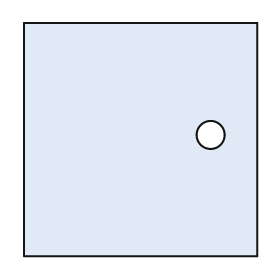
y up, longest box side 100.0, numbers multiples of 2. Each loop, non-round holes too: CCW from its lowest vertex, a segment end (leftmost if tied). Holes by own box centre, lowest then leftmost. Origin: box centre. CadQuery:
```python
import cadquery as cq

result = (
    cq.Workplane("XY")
    .moveTo(-50.0, -50.0)
    .lineTo(50.0, -50.0)
    .lineTo(50.0, 50.0)
    .lineTo(-50.0, 50.0)
    .close()
    .moveTo(30.0, 2.0)
    .circle(6.0)
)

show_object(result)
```